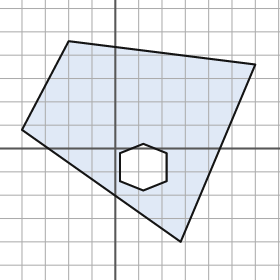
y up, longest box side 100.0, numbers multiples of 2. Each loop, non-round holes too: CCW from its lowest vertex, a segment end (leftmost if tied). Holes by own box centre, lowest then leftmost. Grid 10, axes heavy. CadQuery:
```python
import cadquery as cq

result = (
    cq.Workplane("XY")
    .moveTo(28.0, -40.0)
    .lineTo(60.0, 36.0)
    .lineTo(-20.0, 46.0)
    .lineTo(-40.0, 8.0)
    .close()
    .moveTo(12.0, -18.0)
    .lineTo(22.0, -14.0)
    .lineTo(22.0, -2.0)
    .lineTo(12.0, 2.0)
    .lineTo(2.0, -2.0)
    .lineTo(2.0, -14.0)
    .close()
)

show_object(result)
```